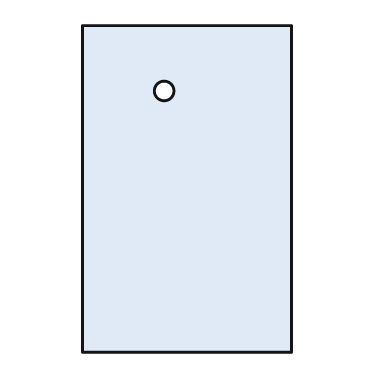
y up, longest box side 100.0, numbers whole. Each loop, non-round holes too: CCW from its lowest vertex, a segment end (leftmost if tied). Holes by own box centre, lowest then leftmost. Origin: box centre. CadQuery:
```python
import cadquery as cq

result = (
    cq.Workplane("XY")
    .moveTo(-32.0, -50.0)
    .lineTo(32.0, -50.0)
    .lineTo(32.0, 50.0)
    .lineTo(-32.0, 50.0)
    .close()
    .moveTo(-7.0, 30.0)
    .circle(3.0)
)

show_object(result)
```